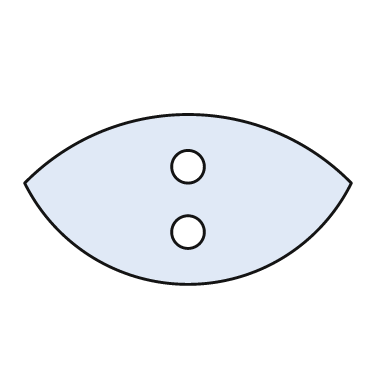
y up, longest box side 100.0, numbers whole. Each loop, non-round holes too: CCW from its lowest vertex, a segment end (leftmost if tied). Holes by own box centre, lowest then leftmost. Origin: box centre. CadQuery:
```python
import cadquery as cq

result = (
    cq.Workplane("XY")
    .moveTo(-50.0, 5.0)
    .threePointArc((0.0, -26.0), (50.0, 5.0))
    .threePointArc((0.0, 26.0), (-50.0, 5.0))
    .close()
    .moveTo(0.0, -10.0)
    .circle(5.0)
    .moveTo(0.0, 10.0)
    .circle(5.0)
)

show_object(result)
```